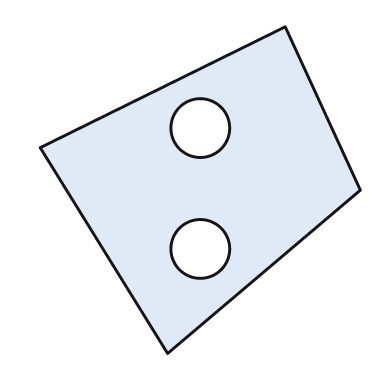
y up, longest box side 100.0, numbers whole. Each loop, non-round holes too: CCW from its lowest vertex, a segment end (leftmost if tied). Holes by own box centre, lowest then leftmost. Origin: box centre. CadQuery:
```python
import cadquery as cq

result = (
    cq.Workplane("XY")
    .moveTo(-10.0, -50.0)
    .lineTo(49.0, 0.0)
    .lineTo(26.0, 50.0)
    .lineTo(-49.0, 13.0)
    .close()
    .moveTo(0.0, -18.0)
    .circle(9.0)
    .moveTo(0.0, 19.0)
    .circle(9.0)
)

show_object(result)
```